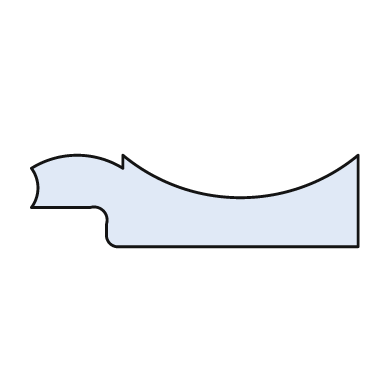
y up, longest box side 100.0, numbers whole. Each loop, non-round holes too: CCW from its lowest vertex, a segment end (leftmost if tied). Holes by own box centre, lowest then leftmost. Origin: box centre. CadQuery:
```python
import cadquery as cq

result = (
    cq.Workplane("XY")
    .moveTo(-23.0, -14.0)
    .lineTo(50.0, -14.0)
    .lineTo(50.0, 14.0)
    .threePointArc((14.0, 1.0), (-22.0, 14.0))
    .lineTo(-22.0, 10.0)
    .threePointArc((-36.0, 14.0), (-50.0, 10.0))
    .threePointArc((-48.0, 4.0), (-50.0, -2.0))
    .lineTo(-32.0, -2.0)
    .threePointArc((-28.0, -3.0), (-27.0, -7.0))
    .lineTo(-27.0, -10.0)
    .threePointArc((-26.0, -13.0), (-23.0, -14.0))
    .close()
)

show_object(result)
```